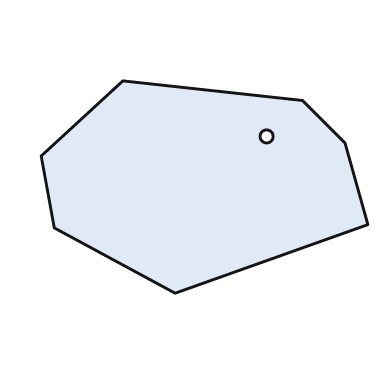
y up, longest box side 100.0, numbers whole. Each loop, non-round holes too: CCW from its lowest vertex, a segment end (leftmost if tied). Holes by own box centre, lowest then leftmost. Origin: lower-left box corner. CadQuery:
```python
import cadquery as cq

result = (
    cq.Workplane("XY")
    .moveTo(41.0, 0.0)
    .lineTo(100.0, 21.0)
    .lineTo(93.0, 46.0)
    .lineTo(80.0, 59.0)
    .lineTo(25.0, 65.0)
    .lineTo(0.0, 42.0)
    .lineTo(4.0, 20.0)
    .close()
    .moveTo(69.0, 48.0)
    .circle(2.0)
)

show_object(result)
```